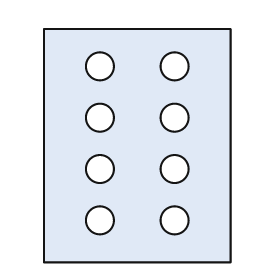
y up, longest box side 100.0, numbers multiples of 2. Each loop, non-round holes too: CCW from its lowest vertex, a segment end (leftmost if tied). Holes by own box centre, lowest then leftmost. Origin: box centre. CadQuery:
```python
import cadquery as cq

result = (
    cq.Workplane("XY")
    .moveTo(-40.0, -50.0)
    .lineTo(40.0, -50.0)
    .lineTo(40.0, 50.0)
    .lineTo(-40.0, 50.0)
    .close()
    .moveTo(-16.0, -32.0)
    .circle(6.0)
    .moveTo(16.0, -32.0)
    .circle(6.0)
    .moveTo(-16.0, -10.0)
    .circle(6.0)
    .moveTo(16.0, -10.0)
    .circle(6.0)
    .moveTo(-16.0, 12.0)
    .circle(6.0)
    .moveTo(16.0, 12.0)
    .circle(6.0)
    .moveTo(-16.0, 34.0)
    .circle(6.0)
    .moveTo(16.0, 34.0)
    .circle(6.0)
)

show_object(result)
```